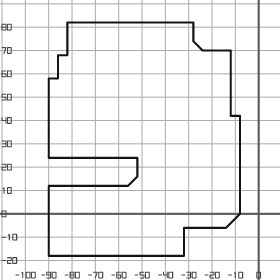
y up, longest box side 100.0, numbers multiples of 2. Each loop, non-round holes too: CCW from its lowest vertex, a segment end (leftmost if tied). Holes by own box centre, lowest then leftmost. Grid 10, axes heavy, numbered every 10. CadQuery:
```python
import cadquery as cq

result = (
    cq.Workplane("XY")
    .moveTo(-90.0, -18.0)
    .lineTo(-32.0, -18.0)
    .lineTo(-32.0, -6.0)
    .lineTo(-14.0, -6.0)
    .lineTo(-8.0, 0.0)
    .lineTo(-8.0, 42.0)
    .lineTo(-12.0, 42.0)
    .lineTo(-12.0, 70.0)
    .lineTo(-24.0, 70.0)
    .lineTo(-28.0, 74.0)
    .lineTo(-28.0, 82.0)
    .lineTo(-82.0, 82.0)
    .lineTo(-82.0, 68.0)
    .lineTo(-86.0, 68.0)
    .lineTo(-86.0, 58.0)
    .lineTo(-90.0, 58.0)
    .lineTo(-90.0, 24.0)
    .lineTo(-52.0, 24.0)
    .lineTo(-52.0, 16.0)
    .lineTo(-56.0, 12.0)
    .lineTo(-90.0, 12.0)
    .close()
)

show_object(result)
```